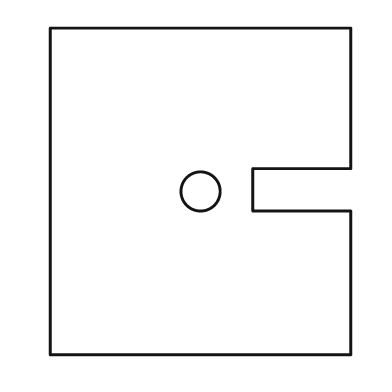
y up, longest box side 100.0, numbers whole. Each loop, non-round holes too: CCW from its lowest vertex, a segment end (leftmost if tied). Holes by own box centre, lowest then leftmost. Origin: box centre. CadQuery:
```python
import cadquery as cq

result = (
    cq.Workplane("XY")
    .moveTo(-46.0, -50.0)
    .lineTo(46.0, -50.0)
    .lineTo(46.0, -6.0)
    .lineTo(16.0, -6.0)
    .lineTo(16.0, 7.0)
    .lineTo(46.0, 7.0)
    .lineTo(46.0, 50.0)
    .lineTo(-46.0, 50.0)
    .close()
    .moveTo(0.0, 0.0)
    .circle(6.0)
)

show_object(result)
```